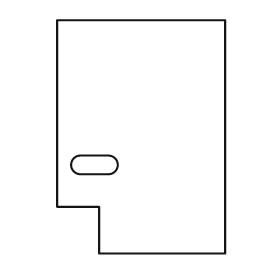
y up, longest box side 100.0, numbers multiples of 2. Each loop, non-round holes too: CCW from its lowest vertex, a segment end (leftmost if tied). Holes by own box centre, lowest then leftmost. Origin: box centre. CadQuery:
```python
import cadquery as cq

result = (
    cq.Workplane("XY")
    .moveTo(-18.0, -50.0)
    .lineTo(36.0, -50.0)
    .lineTo(36.0, 50.0)
    .lineTo(-36.0, 50.0)
    .lineTo(-36.0, -30.0)
    .lineTo(-18.0, -30.0)
    .close()
    .moveTo(-26.0, -16.0)
    .lineTo(-14.0, -16.0)
    .threePointArc((-10.0, -12.0), (-14.0, -8.0))
    .lineTo(-26.0, -8.0)
    .threePointArc((-30.0, -12.0), (-26.0, -16.0))
    .close()
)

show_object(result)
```